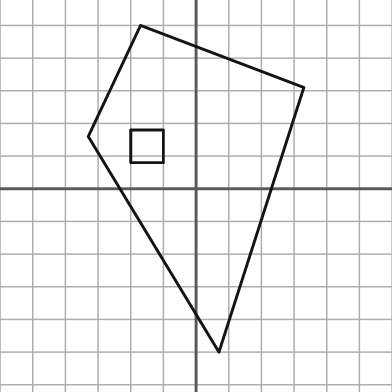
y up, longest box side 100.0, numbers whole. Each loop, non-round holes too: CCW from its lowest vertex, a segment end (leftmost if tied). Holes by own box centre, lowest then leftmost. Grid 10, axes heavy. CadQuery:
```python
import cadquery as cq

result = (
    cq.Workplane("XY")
    .moveTo(7.0, -50.0)
    .lineTo(33.0, 31.0)
    .lineTo(-17.0, 50.0)
    .lineTo(-33.0, 16.0)
    .close()
    .moveTo(-20.0, 8.0)
    .lineTo(-10.0, 8.0)
    .lineTo(-10.0, 18.0)
    .lineTo(-20.0, 18.0)
    .close()
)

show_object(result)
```